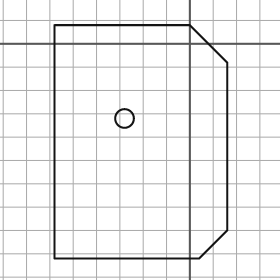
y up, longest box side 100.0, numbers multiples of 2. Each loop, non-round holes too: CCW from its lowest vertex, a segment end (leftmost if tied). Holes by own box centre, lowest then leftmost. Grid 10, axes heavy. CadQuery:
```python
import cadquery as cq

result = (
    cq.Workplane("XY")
    .moveTo(-58.0, -92.0)
    .lineTo(4.0, -92.0)
    .lineTo(16.0, -80.0)
    .lineTo(16.0, -8.0)
    .lineTo(0.0, 8.0)
    .lineTo(-58.0, 8.0)
    .close()
    .moveTo(-28.0, -32.0)
    .circle(4.0)
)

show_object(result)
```